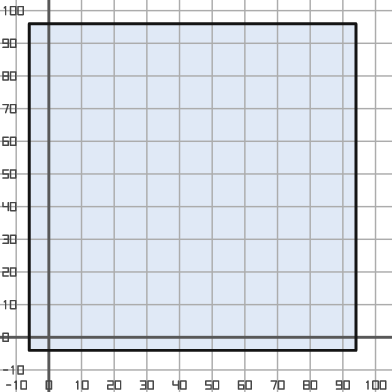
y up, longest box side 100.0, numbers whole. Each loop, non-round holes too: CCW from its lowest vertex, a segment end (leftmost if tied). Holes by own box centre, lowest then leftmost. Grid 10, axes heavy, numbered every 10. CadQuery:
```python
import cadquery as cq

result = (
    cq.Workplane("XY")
    .moveTo(-6.0, -4.0)
    .lineTo(94.0, -4.0)
    .lineTo(94.0, 96.0)
    .lineTo(-6.0, 96.0)
    .close()
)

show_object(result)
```